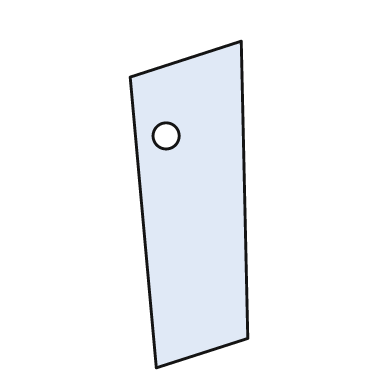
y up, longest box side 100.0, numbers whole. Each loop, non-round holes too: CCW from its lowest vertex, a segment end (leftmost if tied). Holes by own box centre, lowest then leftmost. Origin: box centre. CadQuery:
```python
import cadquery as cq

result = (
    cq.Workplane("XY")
    .moveTo(-10.0, -50.0)
    .lineTo(18.0, -41.0)
    .lineTo(16.0, 50.0)
    .lineTo(-18.0, 39.0)
    .close()
    .moveTo(-7.0, 21.0)
    .circle(4.0)
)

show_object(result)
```